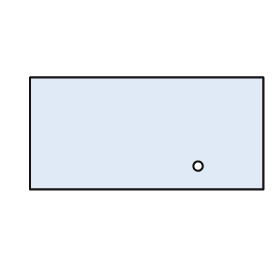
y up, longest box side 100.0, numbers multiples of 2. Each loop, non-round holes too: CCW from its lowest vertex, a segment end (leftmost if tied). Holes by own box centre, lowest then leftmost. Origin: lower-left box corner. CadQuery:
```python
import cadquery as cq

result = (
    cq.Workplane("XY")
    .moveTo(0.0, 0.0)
    .lineTo(100.0, 0.0)
    .lineTo(100.0, 48.0)
    .lineTo(0.0, 48.0)
    .close()
    .moveTo(72.0, 10.0)
    .circle(2.0)
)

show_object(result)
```